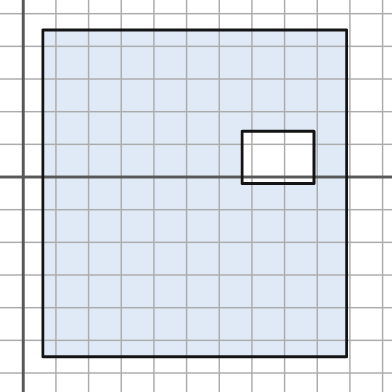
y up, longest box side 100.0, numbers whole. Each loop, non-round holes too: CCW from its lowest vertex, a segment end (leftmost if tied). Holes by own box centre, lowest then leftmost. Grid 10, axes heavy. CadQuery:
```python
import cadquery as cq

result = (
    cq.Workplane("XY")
    .moveTo(6.0, -55.0)
    .lineTo(99.0, -55.0)
    .lineTo(99.0, 45.0)
    .lineTo(6.0, 45.0)
    .close()
    .moveTo(67.0, -2.0)
    .lineTo(89.0, -2.0)
    .lineTo(89.0, 14.0)
    .lineTo(67.0, 14.0)
    .close()
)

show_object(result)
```